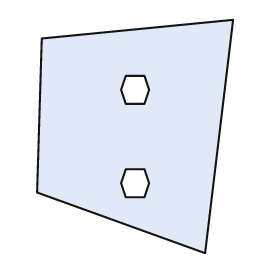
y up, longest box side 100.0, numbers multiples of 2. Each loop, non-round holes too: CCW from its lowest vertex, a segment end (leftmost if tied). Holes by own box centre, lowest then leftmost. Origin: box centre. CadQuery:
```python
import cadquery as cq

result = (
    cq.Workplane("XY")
    .moveTo(30.0, -50.0)
    .lineTo(42.0, 50.0)
    .lineTo(-40.0, 42.0)
    .lineTo(-42.0, -24.0)
    .close()
    .moveTo(-4.0, -26.0)
    .lineTo(4.0, -26.0)
    .lineTo(6.0, -20.0)
    .lineTo(4.0, -14.0)
    .lineTo(-4.0, -14.0)
    .lineTo(-6.0, -20.0)
    .close()
    .moveTo(-4.0, 14.0)
    .lineTo(4.0, 14.0)
    .lineTo(6.0, 20.0)
    .lineTo(4.0, 26.0)
    .lineTo(-4.0, 26.0)
    .lineTo(-6.0, 20.0)
    .close()
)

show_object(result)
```